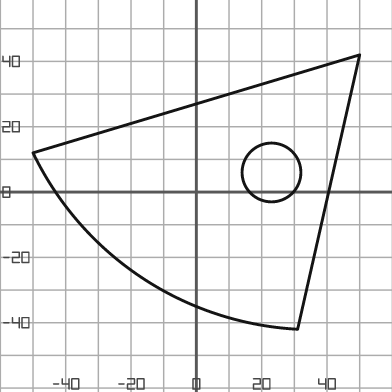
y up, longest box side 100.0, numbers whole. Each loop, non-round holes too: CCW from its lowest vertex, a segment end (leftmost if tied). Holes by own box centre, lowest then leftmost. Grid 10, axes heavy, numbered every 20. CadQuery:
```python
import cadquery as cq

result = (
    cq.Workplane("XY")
    .moveTo(31.0, -42.0)
    .lineTo(50.0, 42.0)
    .lineTo(-50.0, 12.0)
    .threePointArc((-17.0, -26.0), (31.0, -42.0))
    .close()
    .moveTo(23.0, 6.0)
    .circle(9.0)
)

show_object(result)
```